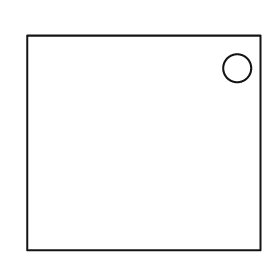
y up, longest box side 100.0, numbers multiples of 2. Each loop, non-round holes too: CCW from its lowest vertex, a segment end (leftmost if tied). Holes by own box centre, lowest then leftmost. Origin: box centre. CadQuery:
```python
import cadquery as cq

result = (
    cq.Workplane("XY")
    .moveTo(-50.0, -46.0)
    .lineTo(50.0, -46.0)
    .lineTo(50.0, 46.0)
    .lineTo(-50.0, 46.0)
    .close()
    .moveTo(40.0, 32.0)
    .circle(6.0)
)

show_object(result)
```